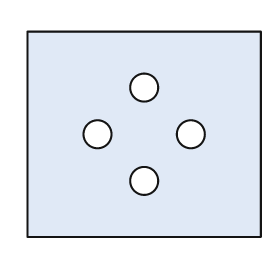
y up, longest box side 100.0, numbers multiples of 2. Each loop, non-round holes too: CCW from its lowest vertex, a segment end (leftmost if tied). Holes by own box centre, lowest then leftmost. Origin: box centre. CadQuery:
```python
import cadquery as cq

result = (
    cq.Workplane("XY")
    .moveTo(-50.0, -44.0)
    .lineTo(50.0, -44.0)
    .lineTo(50.0, 44.0)
    .lineTo(-50.0, 44.0)
    .close()
    .moveTo(0.0, -20.0)
    .circle(6.0)
    .moveTo(-20.0, 0.0)
    .circle(6.0)
    .moveTo(20.0, 0.0)
    .circle(6.0)
    .moveTo(0.0, 20.0)
    .circle(6.0)
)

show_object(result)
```